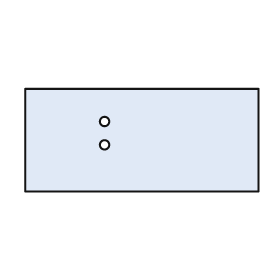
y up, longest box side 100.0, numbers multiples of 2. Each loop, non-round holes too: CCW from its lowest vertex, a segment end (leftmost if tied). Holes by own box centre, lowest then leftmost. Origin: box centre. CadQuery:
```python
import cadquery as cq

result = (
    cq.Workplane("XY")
    .moveTo(-50.0, -22.0)
    .lineTo(50.0, -22.0)
    .lineTo(50.0, 22.0)
    .lineTo(-50.0, 22.0)
    .close()
    .moveTo(-16.0, -2.0)
    .circle(2.0)
    .moveTo(-16.0, 8.0)
    .circle(2.0)
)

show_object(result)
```